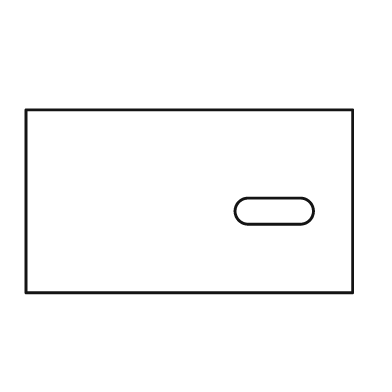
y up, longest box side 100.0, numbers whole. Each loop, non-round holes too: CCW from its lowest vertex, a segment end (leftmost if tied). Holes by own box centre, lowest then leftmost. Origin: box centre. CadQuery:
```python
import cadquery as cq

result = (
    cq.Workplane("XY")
    .moveTo(-50.0, -28.0)
    .lineTo(50.0, -28.0)
    .lineTo(50.0, 28.0)
    .lineTo(-50.0, 28.0)
    .close()
    .moveTo(18.0, -7.0)
    .lineTo(34.0, -7.0)
    .threePointArc((38.0, -3.0), (34.0, 1.0))
    .lineTo(18.0, 1.0)
    .threePointArc((14.0, -3.0), (18.0, -7.0))
    .close()
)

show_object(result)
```